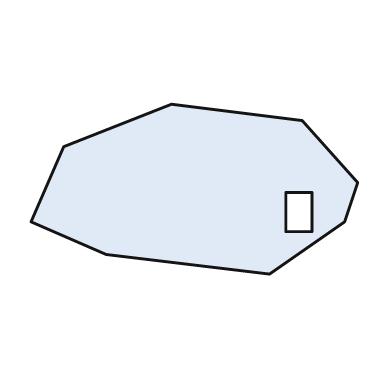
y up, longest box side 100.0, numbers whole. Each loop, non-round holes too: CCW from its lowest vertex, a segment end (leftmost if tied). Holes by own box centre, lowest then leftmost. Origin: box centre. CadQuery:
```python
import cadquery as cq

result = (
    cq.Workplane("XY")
    .moveTo(23.0, -26.0)
    .lineTo(46.0, -10.0)
    .lineTo(50.0, 2.0)
    .lineTo(33.0, 21.0)
    .lineTo(-7.0, 26.0)
    .lineTo(-40.0, 13.0)
    .lineTo(-50.0, -10.0)
    .lineTo(-27.0, -20.0)
    .close()
    .moveTo(28.0, -13.0)
    .lineTo(36.0, -13.0)
    .lineTo(36.0, -1.0)
    .lineTo(28.0, -1.0)
    .close()
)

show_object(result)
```